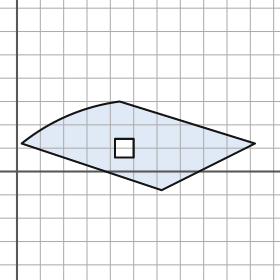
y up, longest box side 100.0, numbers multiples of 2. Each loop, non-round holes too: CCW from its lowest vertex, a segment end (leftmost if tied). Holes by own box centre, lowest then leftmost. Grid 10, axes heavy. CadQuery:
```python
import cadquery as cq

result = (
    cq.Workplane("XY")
    .moveTo(62.0, -8.0)
    .lineTo(102.0, 12.0)
    .lineTo(44.0, 30.0)
    .threePointArc((22.0, 24.0), (2.0, 12.0))
    .close()
    .moveTo(42.0, 6.0)
    .lineTo(50.0, 6.0)
    .lineTo(50.0, 14.0)
    .lineTo(42.0, 14.0)
    .close()
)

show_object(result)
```